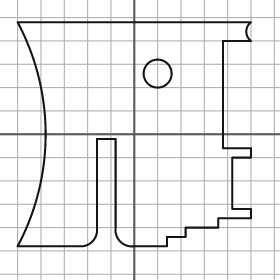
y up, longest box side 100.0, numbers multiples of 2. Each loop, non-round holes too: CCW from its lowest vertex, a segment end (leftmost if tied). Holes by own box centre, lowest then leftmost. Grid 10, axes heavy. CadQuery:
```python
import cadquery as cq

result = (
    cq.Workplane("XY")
    .moveTo(-50.0, -48.0)
    .lineTo(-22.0, -48.0)
    .threePointArc((-18.0, -46.0), (-16.0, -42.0))
    .lineTo(-16.0, -2.0)
    .lineTo(-8.0, -2.0)
    .lineTo(-8.0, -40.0)
    .threePointArc((-6.0, -46.0), (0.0, -48.0))
    .lineTo(14.0, -48.0)
    .lineTo(14.0, -44.0)
    .lineTo(22.0, -44.0)
    .lineTo(22.0, -40.0)
    .lineTo(36.0, -40.0)
    .lineTo(36.0, -36.0)
    .lineTo(50.0, -36.0)
    .lineTo(50.0, -32.0)
    .lineTo(42.0, -32.0)
    .lineTo(42.0, -10.0)
    .lineTo(50.0, -10.0)
    .lineTo(50.0, -6.0)
    .lineTo(38.0, -6.0)
    .lineTo(38.0, 40.0)
    .lineTo(50.0, 40.0)
    .threePointArc((48.0, 44.0), (50.0, 48.0))
    .lineTo(-50.0, 48.0)
    .threePointArc((-38.0, 0.0), (-50.0, -48.0))
    .close()
    .moveTo(10.0, 26.0)
    .circle(6.0)
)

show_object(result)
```